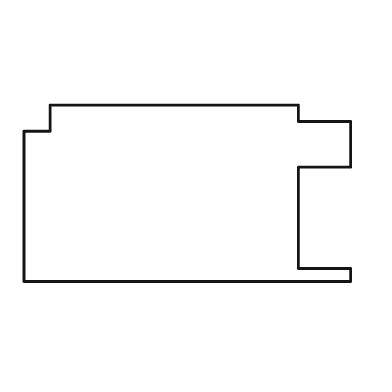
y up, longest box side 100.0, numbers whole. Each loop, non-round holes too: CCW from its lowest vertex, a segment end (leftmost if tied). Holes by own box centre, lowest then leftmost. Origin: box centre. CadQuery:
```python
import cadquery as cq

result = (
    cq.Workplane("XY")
    .moveTo(-50.0, -27.0)
    .lineTo(50.0, -27.0)
    .lineTo(50.0, -23.0)
    .lineTo(34.0, -23.0)
    .lineTo(34.0, 8.0)
    .lineTo(50.0, 8.0)
    .lineTo(50.0, 22.0)
    .lineTo(34.0, 22.0)
    .lineTo(34.0, 27.0)
    .lineTo(-42.0, 27.0)
    .lineTo(-42.0, 19.0)
    .lineTo(-50.0, 19.0)
    .close()
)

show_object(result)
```